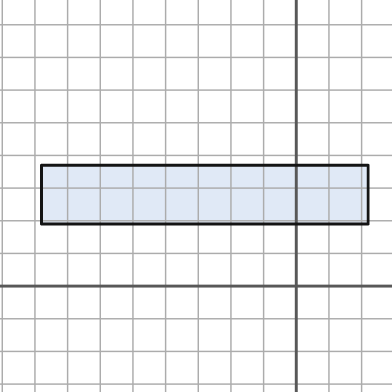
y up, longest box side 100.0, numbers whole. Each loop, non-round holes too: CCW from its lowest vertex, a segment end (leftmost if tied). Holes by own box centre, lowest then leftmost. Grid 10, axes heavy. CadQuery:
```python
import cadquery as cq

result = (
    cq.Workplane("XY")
    .moveTo(-78.0, 19.0)
    .lineTo(22.0, 19.0)
    .lineTo(22.0, 37.0)
    .lineTo(-78.0, 37.0)
    .close()
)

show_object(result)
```